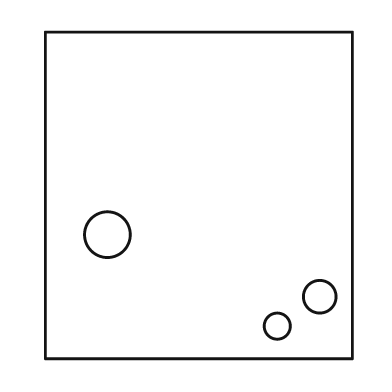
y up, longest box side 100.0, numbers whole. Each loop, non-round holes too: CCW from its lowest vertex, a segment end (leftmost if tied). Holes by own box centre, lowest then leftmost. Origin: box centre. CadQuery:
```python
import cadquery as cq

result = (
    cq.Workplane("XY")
    .moveTo(-47.0, -50.0)
    .lineTo(47.0, -50.0)
    .lineTo(47.0, 50.0)
    .lineTo(-47.0, 50.0)
    .close()
    .moveTo(24.0, -40.0)
    .circle(4.0)
    .moveTo(37.0, -31.0)
    .circle(5.0)
    .moveTo(-28.0, -12.0)
    .circle(7.0)
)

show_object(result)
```